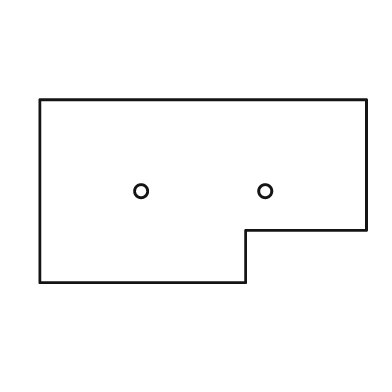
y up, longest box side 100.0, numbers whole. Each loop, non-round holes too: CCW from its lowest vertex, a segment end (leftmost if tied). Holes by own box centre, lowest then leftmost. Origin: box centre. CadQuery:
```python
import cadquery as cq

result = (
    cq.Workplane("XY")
    .moveTo(-50.0, -28.0)
    .lineTo(13.0, -28.0)
    .lineTo(13.0, -12.0)
    .lineTo(50.0, -12.0)
    .lineTo(50.0, 28.0)
    .lineTo(-50.0, 28.0)
    .close()
    .moveTo(-19.0, 0.0)
    .circle(2.0)
    .moveTo(19.0, 0.0)
    .circle(2.0)
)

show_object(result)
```